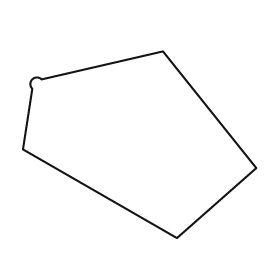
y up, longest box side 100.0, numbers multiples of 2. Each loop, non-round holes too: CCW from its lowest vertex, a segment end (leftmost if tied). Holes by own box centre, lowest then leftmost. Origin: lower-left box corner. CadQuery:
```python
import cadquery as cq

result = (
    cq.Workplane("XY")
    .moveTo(66.0, 0.0)
    .lineTo(100.0, 30.0)
    .lineTo(60.0, 80.0)
    .lineTo(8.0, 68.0)
    .threePointArc((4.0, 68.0), (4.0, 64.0))
    .lineTo(0.0, 38.0)
    .close()
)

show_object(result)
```